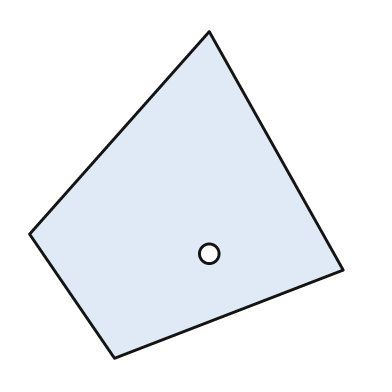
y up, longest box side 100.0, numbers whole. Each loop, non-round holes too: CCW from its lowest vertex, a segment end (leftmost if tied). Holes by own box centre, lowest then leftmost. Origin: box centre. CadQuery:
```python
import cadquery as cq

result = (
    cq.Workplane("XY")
    .moveTo(-22.0, -50.0)
    .lineTo(48.0, -23.0)
    .lineTo(7.0, 50.0)
    .lineTo(-48.0, -12.0)
    .close()
    .moveTo(7.0, -18.0)
    .circle(3.0)
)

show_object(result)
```